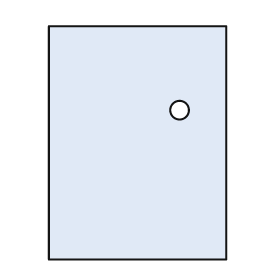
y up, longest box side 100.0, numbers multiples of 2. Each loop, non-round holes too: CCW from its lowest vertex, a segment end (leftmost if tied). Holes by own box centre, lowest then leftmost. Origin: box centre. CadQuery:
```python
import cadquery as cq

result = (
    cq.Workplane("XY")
    .moveTo(-38.0, -50.0)
    .lineTo(38.0, -50.0)
    .lineTo(38.0, 50.0)
    .lineTo(-38.0, 50.0)
    .close()
    .moveTo(18.0, 14.0)
    .circle(4.0)
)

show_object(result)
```